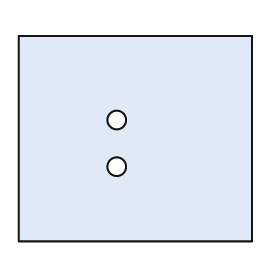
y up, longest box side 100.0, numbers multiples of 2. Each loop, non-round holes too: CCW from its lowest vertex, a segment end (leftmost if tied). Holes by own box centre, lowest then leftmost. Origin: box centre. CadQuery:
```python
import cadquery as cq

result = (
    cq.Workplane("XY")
    .moveTo(-50.0, -44.0)
    .lineTo(50.0, -44.0)
    .lineTo(50.0, 44.0)
    .lineTo(-50.0, 44.0)
    .close()
    .moveTo(-8.0, -12.0)
    .circle(4.0)
    .moveTo(-8.0, 8.0)
    .circle(4.0)
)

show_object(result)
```